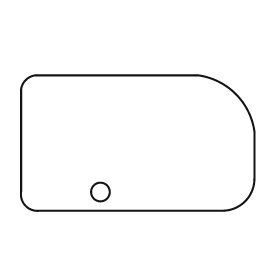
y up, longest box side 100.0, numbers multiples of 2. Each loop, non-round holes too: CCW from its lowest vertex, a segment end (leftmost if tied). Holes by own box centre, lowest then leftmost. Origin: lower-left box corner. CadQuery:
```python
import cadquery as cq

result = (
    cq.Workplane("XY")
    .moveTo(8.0, 0.0)
    .lineTo(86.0, 0.0)
    .threePointArc((96.0, 4.0), (100.0, 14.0))
    .lineTo(100.0, 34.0)
    .threePointArc((92.0, 50.0), (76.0, 58.0))
    .lineTo(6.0, 58.0)
    .threePointArc((2.0, 56.0), (0.0, 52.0))
    .lineTo(0.0, 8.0)
    .threePointArc((2.0, 2.0), (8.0, 0.0))
    .close()
    .moveTo(34.0, 8.0)
    .circle(4.0)
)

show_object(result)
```